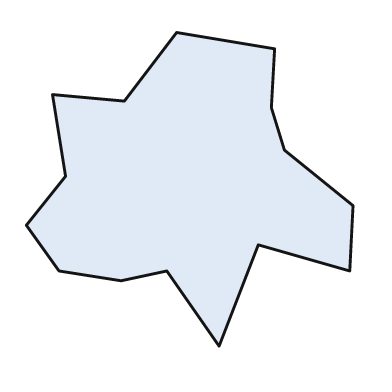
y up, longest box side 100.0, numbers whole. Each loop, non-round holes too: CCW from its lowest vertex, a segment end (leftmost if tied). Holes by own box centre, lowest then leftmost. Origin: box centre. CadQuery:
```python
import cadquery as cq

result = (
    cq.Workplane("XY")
    .moveTo(9.0, -48.0)
    .lineTo(21.0, -17.0)
    .lineTo(49.0, -25.0)
    .lineTo(50.0, -5.0)
    .lineTo(29.0, 12.0)
    .lineTo(25.0, 25.0)
    .lineTo(26.0, 43.0)
    .lineTo(-4.0, 48.0)
    .lineTo(-20.0, 27.0)
    .lineTo(-42.0, 29.0)
    .lineTo(-38.0, 4.0)
    .lineTo(-50.0, -11.0)
    .lineTo(-40.0, -25.0)
    .lineTo(-21.0, -28.0)
    .lineTo(-7.0, -25.0)
    .close()
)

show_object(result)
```